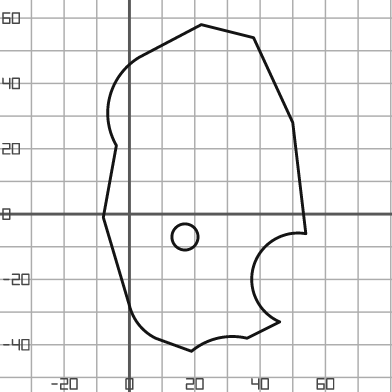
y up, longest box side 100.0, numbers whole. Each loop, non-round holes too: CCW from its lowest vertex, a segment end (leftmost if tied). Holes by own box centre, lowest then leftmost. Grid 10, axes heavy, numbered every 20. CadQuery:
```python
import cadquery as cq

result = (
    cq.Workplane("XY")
    .moveTo(19.0, -42.0)
    .threePointArc((27.0, -38.0), (36.0, -38.0))
    .lineTo(46.0, -33.0)
    .threePointArc((38.0, -16.0), (54.0, -6.0))
    .lineTo(50.0, 28.0)
    .lineTo(38.0, 54.0)
    .lineTo(22.0, 58.0)
    .lineTo(3.0, 48.0)
    .threePointArc((-6.0, 36.0), (-4.0, 21.0))
    .lineTo(-8.0, -1.0)
    .lineTo(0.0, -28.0)
    .threePointArc((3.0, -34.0), (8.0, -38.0))
    .close()
    .moveTo(17.0, -7.0)
    .circle(4.0)
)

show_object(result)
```